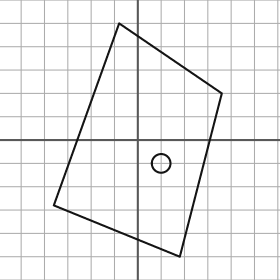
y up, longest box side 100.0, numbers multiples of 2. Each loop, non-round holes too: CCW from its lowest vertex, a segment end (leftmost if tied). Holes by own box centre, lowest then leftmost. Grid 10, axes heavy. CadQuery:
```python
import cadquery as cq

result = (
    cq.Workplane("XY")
    .moveTo(18.0, -50.0)
    .lineTo(36.0, 20.0)
    .lineTo(-8.0, 50.0)
    .lineTo(-36.0, -28.0)
    .close()
    .moveTo(10.0, -10.0)
    .circle(4.0)
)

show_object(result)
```